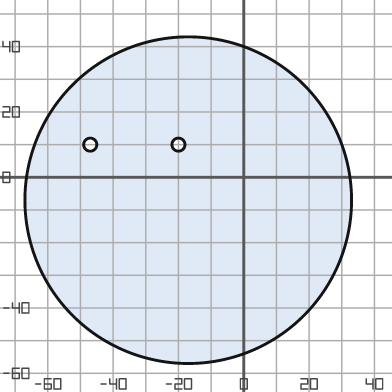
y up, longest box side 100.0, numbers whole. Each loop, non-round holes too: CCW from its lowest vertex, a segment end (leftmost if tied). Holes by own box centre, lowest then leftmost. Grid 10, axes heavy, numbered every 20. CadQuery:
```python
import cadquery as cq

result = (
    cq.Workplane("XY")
    .moveTo(-17.0, -7.0)
    .circle(50.0)
    .moveTo(-47.0, 10.0)
    .circle(2.0)
    .moveTo(-20.0, 10.0)
    .circle(2.0)
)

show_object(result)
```